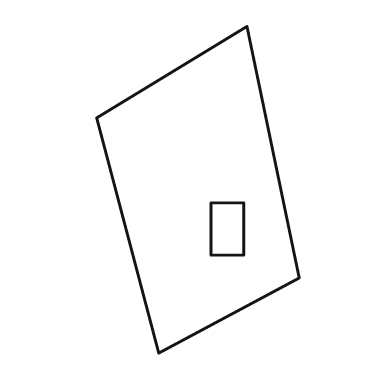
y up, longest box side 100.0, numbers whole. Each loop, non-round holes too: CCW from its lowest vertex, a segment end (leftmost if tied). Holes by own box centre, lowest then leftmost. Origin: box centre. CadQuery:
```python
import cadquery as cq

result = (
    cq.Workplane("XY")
    .moveTo(-12.0, -50.0)
    .lineTo(31.0, -27.0)
    .lineTo(15.0, 50.0)
    .lineTo(-31.0, 22.0)
    .close()
    .moveTo(4.0, -20.0)
    .lineTo(14.0, -20.0)
    .lineTo(14.0, -4.0)
    .lineTo(4.0, -4.0)
    .close()
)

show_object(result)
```